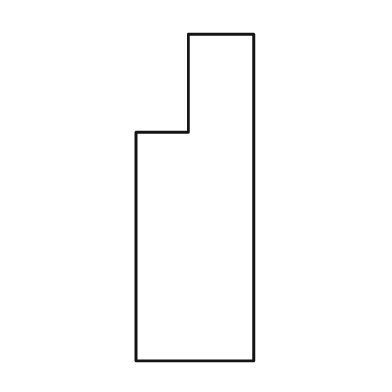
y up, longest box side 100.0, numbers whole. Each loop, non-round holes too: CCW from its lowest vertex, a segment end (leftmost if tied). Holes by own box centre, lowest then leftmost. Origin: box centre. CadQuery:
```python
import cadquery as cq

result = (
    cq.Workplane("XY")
    .moveTo(-18.0, -50.0)
    .lineTo(18.0, -50.0)
    .lineTo(18.0, 50.0)
    .lineTo(-2.0, 50.0)
    .lineTo(-2.0, 20.0)
    .lineTo(-18.0, 20.0)
    .close()
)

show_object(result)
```